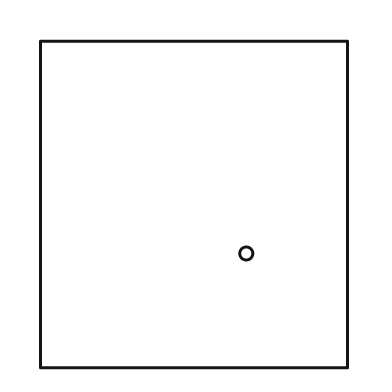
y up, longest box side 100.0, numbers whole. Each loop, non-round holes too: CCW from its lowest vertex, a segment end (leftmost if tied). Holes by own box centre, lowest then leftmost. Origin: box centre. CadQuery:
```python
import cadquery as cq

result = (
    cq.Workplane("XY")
    .moveTo(-47.0, -50.0)
    .lineTo(47.0, -50.0)
    .lineTo(47.0, 50.0)
    .lineTo(-47.0, 50.0)
    .close()
    .moveTo(16.0, -15.0)
    .circle(2.0)
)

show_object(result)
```